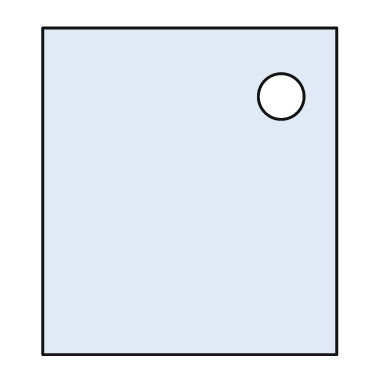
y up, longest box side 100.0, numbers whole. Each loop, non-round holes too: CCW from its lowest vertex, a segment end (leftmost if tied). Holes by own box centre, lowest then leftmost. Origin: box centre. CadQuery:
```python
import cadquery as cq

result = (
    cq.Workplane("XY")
    .moveTo(-45.0, -50.0)
    .lineTo(45.0, -50.0)
    .lineTo(45.0, 50.0)
    .lineTo(-45.0, 50.0)
    .close()
    .moveTo(28.0, 29.0)
    .circle(7.0)
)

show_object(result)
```